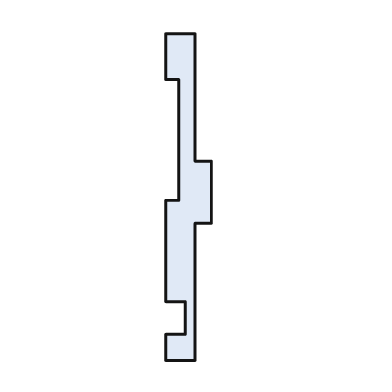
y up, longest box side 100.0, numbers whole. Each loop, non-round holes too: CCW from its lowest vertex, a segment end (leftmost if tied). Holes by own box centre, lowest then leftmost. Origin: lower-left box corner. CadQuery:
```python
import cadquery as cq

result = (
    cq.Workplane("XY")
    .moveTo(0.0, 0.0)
    .lineTo(9.0, 0.0)
    .lineTo(9.0, 42.0)
    .lineTo(14.0, 42.0)
    .lineTo(14.0, 61.0)
    .lineTo(9.0, 61.0)
    .lineTo(9.0, 100.0)
    .lineTo(0.0, 100.0)
    .lineTo(0.0, 86.0)
    .lineTo(4.0, 86.0)
    .lineTo(4.0, 49.0)
    .lineTo(0.0, 49.0)
    .lineTo(0.0, 18.0)
    .lineTo(6.0, 18.0)
    .lineTo(6.0, 8.0)
    .lineTo(0.0, 8.0)
    .close()
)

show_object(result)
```